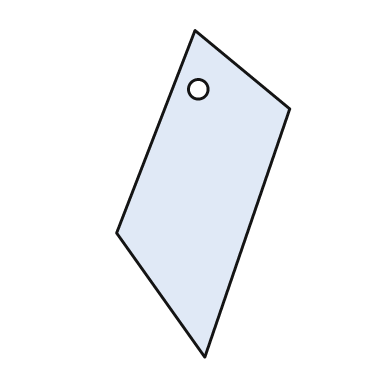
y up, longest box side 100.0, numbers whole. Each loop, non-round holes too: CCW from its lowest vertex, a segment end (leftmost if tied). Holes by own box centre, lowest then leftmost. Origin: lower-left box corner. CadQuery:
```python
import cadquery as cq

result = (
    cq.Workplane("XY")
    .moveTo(27.0, 0.0)
    .lineTo(53.0, 76.0)
    .lineTo(24.0, 100.0)
    .lineTo(0.0, 38.0)
    .close()
    .moveTo(25.0, 82.0)
    .circle(3.0)
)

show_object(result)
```